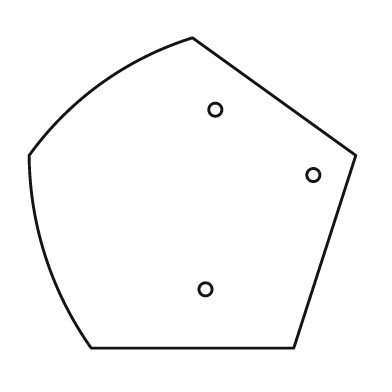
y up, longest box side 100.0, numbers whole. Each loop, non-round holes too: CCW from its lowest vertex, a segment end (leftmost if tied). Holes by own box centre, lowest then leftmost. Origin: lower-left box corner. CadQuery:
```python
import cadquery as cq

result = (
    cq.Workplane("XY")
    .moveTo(19.0, 0.0)
    .lineTo(81.0, 0.0)
    .lineTo(100.0, 59.0)
    .lineTo(50.0, 95.0)
    .threePointArc((22.0, 81.0), (0.0, 59.0))
    .threePointArc((5.0, 28.0), (19.0, 0.0))
    .close()
    .moveTo(54.0, 18.0)
    .circle(2.0)
    .moveTo(87.0, 53.0)
    .circle(2.0)
    .moveTo(57.0, 73.0)
    .circle(2.0)
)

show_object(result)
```